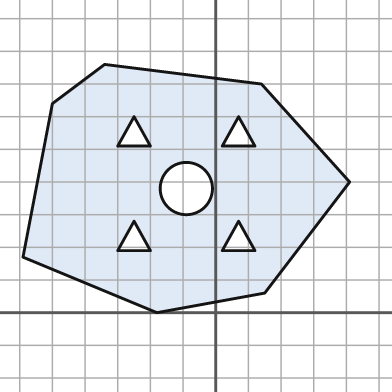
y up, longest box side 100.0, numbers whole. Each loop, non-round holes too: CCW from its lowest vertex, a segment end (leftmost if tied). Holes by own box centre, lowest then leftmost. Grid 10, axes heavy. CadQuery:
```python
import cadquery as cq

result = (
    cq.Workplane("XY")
    .moveTo(-18.0, 0.0)
    .lineTo(15.0, 6.0)
    .lineTo(41.0, 40.0)
    .lineTo(14.0, 70.0)
    .lineTo(-34.0, 76.0)
    .lineTo(-50.0, 64.0)
    .lineTo(-59.0, 17.0)
    .close()
    .moveTo(-30.0, 19.0)
    .lineTo(-20.0, 19.0)
    .lineTo(-25.0, 28.0)
    .close()
    .moveTo(2.0, 19.0)
    .lineTo(12.0, 19.0)
    .lineTo(7.0, 28.0)
    .close()
    .moveTo(-9.0, 38.0)
    .circle(8.0)
    .moveTo(-30.0, 51.0)
    .lineTo(-20.0, 51.0)
    .lineTo(-25.0, 60.0)
    .close()
    .moveTo(2.0, 51.0)
    .lineTo(12.0, 51.0)
    .lineTo(7.0, 60.0)
    .close()
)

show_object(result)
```